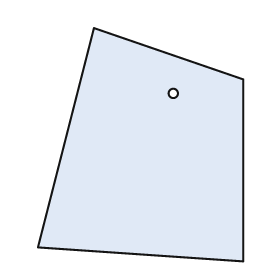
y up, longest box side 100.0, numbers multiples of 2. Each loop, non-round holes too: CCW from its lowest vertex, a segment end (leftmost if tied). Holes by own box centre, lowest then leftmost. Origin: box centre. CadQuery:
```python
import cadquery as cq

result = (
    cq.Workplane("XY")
    .moveTo(44.0, -50.0)
    .lineTo(44.0, 28.0)
    .lineTo(-20.0, 50.0)
    .lineTo(-44.0, -44.0)
    .close()
    .moveTo(14.0, 22.0)
    .circle(2.0)
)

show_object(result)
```